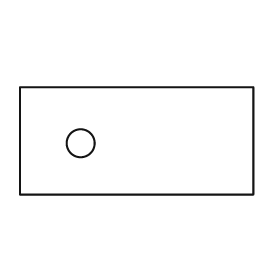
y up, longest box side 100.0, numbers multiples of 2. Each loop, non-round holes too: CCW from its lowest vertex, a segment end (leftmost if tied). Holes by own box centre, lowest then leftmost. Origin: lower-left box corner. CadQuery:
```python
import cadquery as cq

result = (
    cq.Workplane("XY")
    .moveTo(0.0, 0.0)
    .lineTo(100.0, 0.0)
    .lineTo(100.0, 46.0)
    .lineTo(0.0, 46.0)
    .close()
    .moveTo(26.0, 22.0)
    .circle(6.0)
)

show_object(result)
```